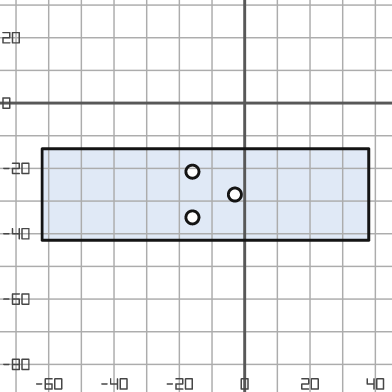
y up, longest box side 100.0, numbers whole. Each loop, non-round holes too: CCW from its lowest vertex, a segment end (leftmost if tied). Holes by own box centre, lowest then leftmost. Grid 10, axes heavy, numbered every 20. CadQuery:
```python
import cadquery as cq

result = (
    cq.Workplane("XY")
    .moveTo(-62.0, -42.0)
    .lineTo(38.0, -42.0)
    .lineTo(38.0, -14.0)
    .lineTo(-62.0, -14.0)
    .close()
    .moveTo(-16.0, -35.0)
    .circle(2.0)
    .moveTo(-3.0, -28.0)
    .circle(2.0)
    .moveTo(-16.0, -21.0)
    .circle(2.0)
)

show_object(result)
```